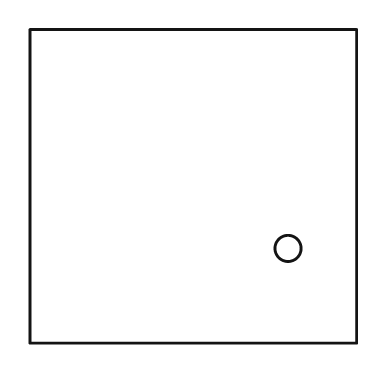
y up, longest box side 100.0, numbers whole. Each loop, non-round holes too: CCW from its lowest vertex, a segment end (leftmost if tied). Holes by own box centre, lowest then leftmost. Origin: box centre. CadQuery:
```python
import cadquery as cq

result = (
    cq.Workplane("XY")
    .moveTo(-50.0, -48.0)
    .lineTo(50.0, -48.0)
    .lineTo(50.0, 48.0)
    .lineTo(-50.0, 48.0)
    .close()
    .moveTo(29.0, -19.0)
    .circle(4.0)
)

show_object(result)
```